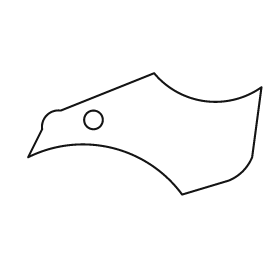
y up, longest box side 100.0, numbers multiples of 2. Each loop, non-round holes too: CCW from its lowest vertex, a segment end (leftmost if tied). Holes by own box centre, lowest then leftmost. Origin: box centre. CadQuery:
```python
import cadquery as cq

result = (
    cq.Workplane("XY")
    .moveTo(16.0, -26.0)
    .lineTo(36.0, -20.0)
    .threePointArc((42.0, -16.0), (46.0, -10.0))
    .lineTo(50.0, 20.0)
    .threePointArc((26.0, 14.0), (4.0, 26.0))
    .lineTo(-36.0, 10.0)
    .threePointArc((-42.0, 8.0), (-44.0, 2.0))
    .lineTo(-50.0, -10.0)
    .threePointArc((-14.0, -6.0), (16.0, -26.0))
    .close()
    .moveTo(-22.0, 6.0)
    .circle(4.0)
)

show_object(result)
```